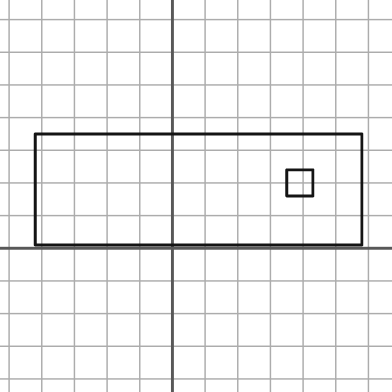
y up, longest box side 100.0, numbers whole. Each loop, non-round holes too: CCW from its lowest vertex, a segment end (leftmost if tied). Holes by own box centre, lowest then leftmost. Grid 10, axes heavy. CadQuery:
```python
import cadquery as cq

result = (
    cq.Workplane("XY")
    .moveTo(-42.0, 1.0)
    .lineTo(58.0, 1.0)
    .lineTo(58.0, 35.0)
    .lineTo(-42.0, 35.0)
    .close()
    .moveTo(35.0, 16.0)
    .lineTo(43.0, 16.0)
    .lineTo(43.0, 24.0)
    .lineTo(35.0, 24.0)
    .close()
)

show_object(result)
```